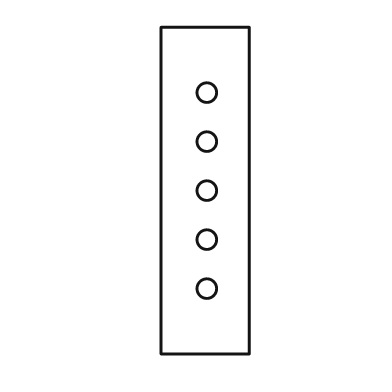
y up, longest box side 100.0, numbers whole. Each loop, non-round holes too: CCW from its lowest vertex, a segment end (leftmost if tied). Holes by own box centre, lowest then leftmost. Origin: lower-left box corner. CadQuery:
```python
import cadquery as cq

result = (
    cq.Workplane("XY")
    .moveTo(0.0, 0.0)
    .lineTo(27.0, 0.0)
    .lineTo(27.0, 100.0)
    .lineTo(0.0, 100.0)
    .close()
    .moveTo(14.0, 20.0)
    .circle(3.0)
    .moveTo(14.0, 35.0)
    .circle(3.0)
    .moveTo(14.0, 50.0)
    .circle(3.0)
    .moveTo(14.0, 65.0)
    .circle(3.0)
    .moveTo(14.0, 80.0)
    .circle(3.0)
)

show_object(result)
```